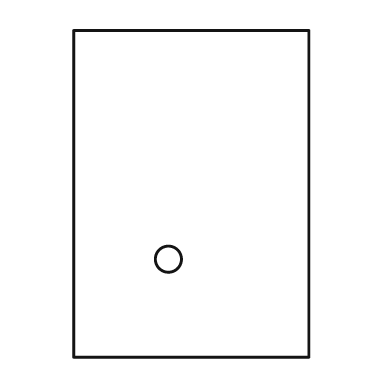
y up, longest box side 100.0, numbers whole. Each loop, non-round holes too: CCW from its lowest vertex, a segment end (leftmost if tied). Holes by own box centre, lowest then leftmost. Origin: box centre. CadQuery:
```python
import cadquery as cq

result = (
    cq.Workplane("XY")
    .moveTo(-36.0, -50.0)
    .lineTo(36.0, -50.0)
    .lineTo(36.0, 50.0)
    .lineTo(-36.0, 50.0)
    .close()
    .moveTo(-7.0, -20.0)
    .circle(4.0)
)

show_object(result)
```